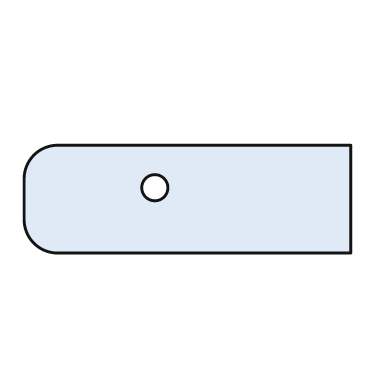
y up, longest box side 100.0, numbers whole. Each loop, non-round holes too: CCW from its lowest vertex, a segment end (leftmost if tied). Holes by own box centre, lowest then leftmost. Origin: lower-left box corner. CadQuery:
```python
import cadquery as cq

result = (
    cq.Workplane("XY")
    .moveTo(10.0, 0.0)
    .lineTo(100.0, 0.0)
    .lineTo(100.0, 33.0)
    .lineTo(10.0, 33.0)
    .threePointArc((3.0, 30.0), (0.0, 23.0))
    .lineTo(0.0, 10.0)
    .threePointArc((3.0, 3.0), (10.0, 0.0))
    .close()
    .moveTo(40.0, 20.0)
    .circle(4.0)
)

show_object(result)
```